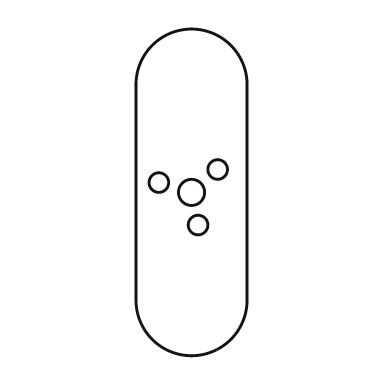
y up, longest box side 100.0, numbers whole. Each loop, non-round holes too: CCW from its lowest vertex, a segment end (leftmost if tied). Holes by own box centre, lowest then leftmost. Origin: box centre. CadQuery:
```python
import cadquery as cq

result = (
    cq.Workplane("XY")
    .moveTo(-17.0, -33.0)
    .threePointArc((0.0, -50.0), (17.0, -33.0))
    .lineTo(17.0, 33.0)
    .threePointArc((0.0, 50.0), (-17.0, 33.0))
    .close()
    .moveTo(2.0, -10.0)
    .circle(3.0)
    .moveTo(0.0, 0.0)
    .circle(4.0)
    .moveTo(-10.0, 3.0)
    .circle(3.0)
    .moveTo(8.0, 7.0)
    .circle(3.0)
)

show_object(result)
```